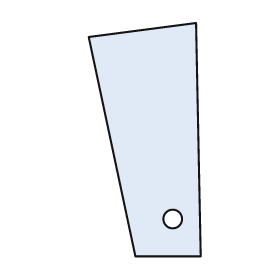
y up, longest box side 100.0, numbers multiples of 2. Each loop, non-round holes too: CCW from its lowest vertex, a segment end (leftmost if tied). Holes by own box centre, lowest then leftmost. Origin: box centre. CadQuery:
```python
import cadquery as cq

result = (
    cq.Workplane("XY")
    .moveTo(-4.0, -50.0)
    .lineTo(24.0, -50.0)
    .lineTo(22.0, 50.0)
    .lineTo(-24.0, 44.0)
    .close()
    .moveTo(12.0, -34.0)
    .circle(4.0)
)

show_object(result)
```